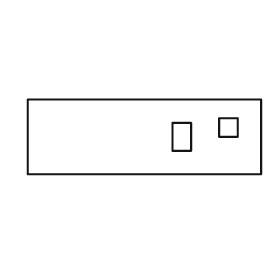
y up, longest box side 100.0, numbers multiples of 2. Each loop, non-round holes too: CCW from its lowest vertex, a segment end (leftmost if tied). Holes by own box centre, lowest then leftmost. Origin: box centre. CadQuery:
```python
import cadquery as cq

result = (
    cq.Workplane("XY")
    .moveTo(-50.0, -16.0)
    .lineTo(50.0, -16.0)
    .lineTo(50.0, 16.0)
    .lineTo(-50.0, 16.0)
    .close()
    .moveTo(12.0, -6.0)
    .lineTo(20.0, -6.0)
    .lineTo(20.0, 6.0)
    .lineTo(12.0, 6.0)
    .close()
    .moveTo(32.0, 0.0)
    .lineTo(40.0, 0.0)
    .lineTo(40.0, 8.0)
    .lineTo(32.0, 8.0)
    .close()
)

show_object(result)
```